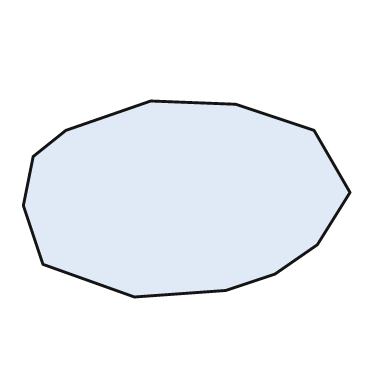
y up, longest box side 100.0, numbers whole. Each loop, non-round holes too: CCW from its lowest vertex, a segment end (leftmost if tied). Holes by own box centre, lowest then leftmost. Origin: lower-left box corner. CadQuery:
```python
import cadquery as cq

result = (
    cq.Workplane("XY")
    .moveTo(34.0, 0.0)
    .lineTo(62.0, 2.0)
    .lineTo(77.0, 7.0)
    .lineTo(90.0, 16.0)
    .lineTo(100.0, 32.0)
    .lineTo(89.0, 51.0)
    .lineTo(65.0, 59.0)
    .lineTo(39.0, 60.0)
    .lineTo(13.0, 51.0)
    .lineTo(3.0, 43.0)
    .lineTo(0.0, 28.0)
    .lineTo(6.0, 10.0)
    .close()
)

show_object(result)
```